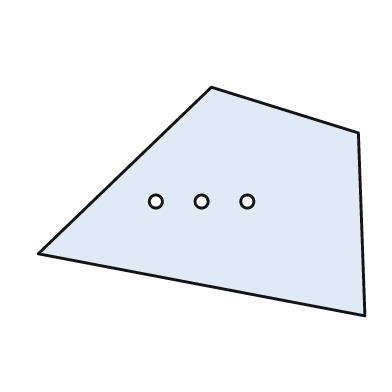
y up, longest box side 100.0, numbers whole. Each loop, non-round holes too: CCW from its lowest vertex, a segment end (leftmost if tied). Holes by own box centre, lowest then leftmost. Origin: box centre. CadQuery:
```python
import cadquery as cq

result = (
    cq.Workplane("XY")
    .moveTo(50.0, -35.0)
    .lineTo(48.0, 21.0)
    .lineTo(3.0, 35.0)
    .lineTo(-50.0, -16.0)
    .close()
    .moveTo(-14.0, 0.0)
    .circle(2.0)
    .moveTo(0.0, 0.0)
    .circle(2.0)
    .moveTo(14.0, 0.0)
    .circle(2.0)
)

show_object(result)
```